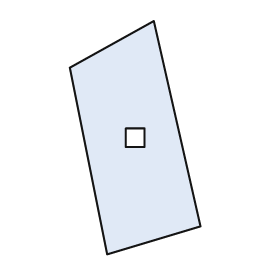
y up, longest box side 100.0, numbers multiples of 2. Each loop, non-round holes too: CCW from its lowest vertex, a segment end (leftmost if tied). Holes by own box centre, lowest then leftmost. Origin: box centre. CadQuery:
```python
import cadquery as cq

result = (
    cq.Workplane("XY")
    .moveTo(-12.0, -50.0)
    .lineTo(28.0, -38.0)
    .lineTo(8.0, 50.0)
    .lineTo(-28.0, 30.0)
    .close()
    .moveTo(-4.0, -4.0)
    .lineTo(4.0, -4.0)
    .lineTo(4.0, 4.0)
    .lineTo(-4.0, 4.0)
    .close()
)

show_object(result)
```